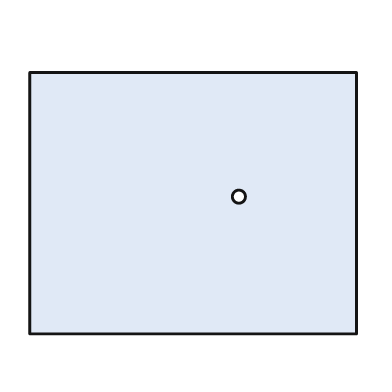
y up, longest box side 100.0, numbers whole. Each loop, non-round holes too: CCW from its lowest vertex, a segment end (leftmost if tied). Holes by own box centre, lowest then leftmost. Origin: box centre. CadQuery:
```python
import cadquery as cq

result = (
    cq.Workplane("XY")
    .moveTo(-50.0, -40.0)
    .lineTo(50.0, -40.0)
    .lineTo(50.0, 40.0)
    .lineTo(-50.0, 40.0)
    .close()
    .moveTo(14.0, 2.0)
    .circle(2.0)
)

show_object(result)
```